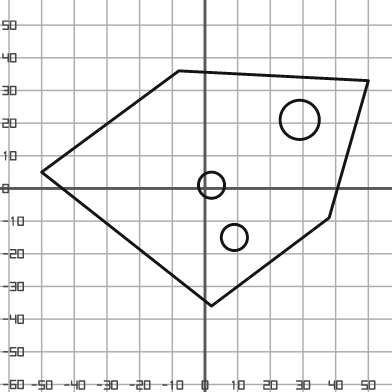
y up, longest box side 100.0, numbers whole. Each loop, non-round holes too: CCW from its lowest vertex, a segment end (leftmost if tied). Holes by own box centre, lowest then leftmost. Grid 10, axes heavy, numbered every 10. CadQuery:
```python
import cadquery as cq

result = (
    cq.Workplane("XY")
    .moveTo(2.0, -36.0)
    .lineTo(38.0, -9.0)
    .lineTo(50.0, 33.0)
    .lineTo(-8.0, 36.0)
    .lineTo(-50.0, 5.0)
    .close()
    .moveTo(9.0, -15.0)
    .circle(4.0)
    .moveTo(2.0, 1.0)
    .circle(4.0)
    .moveTo(29.0, 21.0)
    .circle(6.0)
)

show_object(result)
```